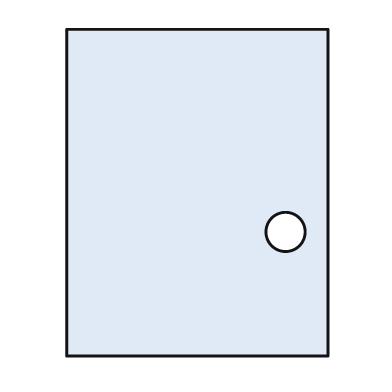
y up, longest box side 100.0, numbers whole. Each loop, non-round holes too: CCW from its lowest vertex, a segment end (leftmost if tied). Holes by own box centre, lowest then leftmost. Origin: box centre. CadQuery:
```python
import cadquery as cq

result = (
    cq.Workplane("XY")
    .moveTo(-40.0, -50.0)
    .lineTo(40.0, -50.0)
    .lineTo(40.0, 50.0)
    .lineTo(-40.0, 50.0)
    .close()
    .moveTo(27.0, -12.0)
    .circle(6.0)
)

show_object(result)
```